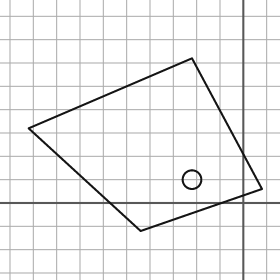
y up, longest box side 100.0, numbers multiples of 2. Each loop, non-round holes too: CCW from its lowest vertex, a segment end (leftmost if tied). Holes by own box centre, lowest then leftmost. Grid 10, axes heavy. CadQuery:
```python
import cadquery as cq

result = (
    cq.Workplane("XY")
    .moveTo(-44.0, -12.0)
    .lineTo(8.0, 6.0)
    .lineTo(-22.0, 62.0)
    .lineTo(-92.0, 32.0)
    .close()
    .moveTo(-22.0, 10.0)
    .circle(4.0)
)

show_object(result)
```